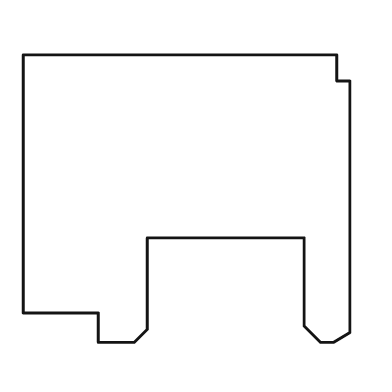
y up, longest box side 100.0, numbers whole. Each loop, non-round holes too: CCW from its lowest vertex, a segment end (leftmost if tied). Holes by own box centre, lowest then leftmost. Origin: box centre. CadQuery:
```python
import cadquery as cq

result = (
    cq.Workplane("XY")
    .moveTo(-27.0, -44.0)
    .lineTo(-16.0, -44.0)
    .lineTo(-12.0, -40.0)
    .lineTo(-12.0, -12.0)
    .lineTo(36.0, -12.0)
    .lineTo(36.0, -39.0)
    .lineTo(41.0, -44.0)
    .lineTo(45.0, -44.0)
    .lineTo(50.0, -41.0)
    .lineTo(50.0, 36.0)
    .lineTo(46.0, 36.0)
    .lineTo(46.0, 44.0)
    .lineTo(-50.0, 44.0)
    .lineTo(-50.0, -35.0)
    .lineTo(-27.0, -35.0)
    .close()
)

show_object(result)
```